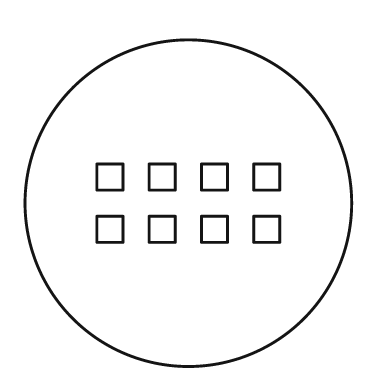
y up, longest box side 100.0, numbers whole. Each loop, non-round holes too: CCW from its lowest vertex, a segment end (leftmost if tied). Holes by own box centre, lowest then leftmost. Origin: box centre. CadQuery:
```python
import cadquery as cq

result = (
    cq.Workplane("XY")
    .moveTo(0.0, 0.0)
    .circle(50.0)
    .moveTo(-28.0, -12.0)
    .lineTo(-20.0, -12.0)
    .lineTo(-20.0, -4.0)
    .lineTo(-28.0, -4.0)
    .close()
    .moveTo(-12.0, -12.0)
    .lineTo(-4.0, -12.0)
    .lineTo(-4.0, -4.0)
    .lineTo(-12.0, -4.0)
    .close()
    .moveTo(4.0, -12.0)
    .lineTo(12.0, -12.0)
    .lineTo(12.0, -4.0)
    .lineTo(4.0, -4.0)
    .close()
    .moveTo(20.0, -12.0)
    .lineTo(28.0, -12.0)
    .lineTo(28.0, -4.0)
    .lineTo(20.0, -4.0)
    .close()
    .moveTo(-28.0, 4.0)
    .lineTo(-20.0, 4.0)
    .lineTo(-20.0, 12.0)
    .lineTo(-28.0, 12.0)
    .close()
    .moveTo(-12.0, 4.0)
    .lineTo(-4.0, 4.0)
    .lineTo(-4.0, 12.0)
    .lineTo(-12.0, 12.0)
    .close()
    .moveTo(4.0, 4.0)
    .lineTo(12.0, 4.0)
    .lineTo(12.0, 12.0)
    .lineTo(4.0, 12.0)
    .close()
    .moveTo(20.0, 4.0)
    .lineTo(28.0, 4.0)
    .lineTo(28.0, 12.0)
    .lineTo(20.0, 12.0)
    .close()
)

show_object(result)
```